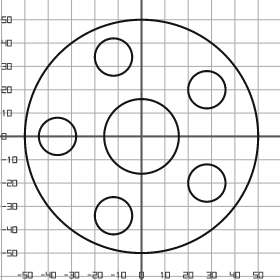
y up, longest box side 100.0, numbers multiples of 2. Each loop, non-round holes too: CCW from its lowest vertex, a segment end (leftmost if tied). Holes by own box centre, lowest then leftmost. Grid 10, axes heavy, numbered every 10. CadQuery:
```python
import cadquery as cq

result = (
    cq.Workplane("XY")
    .moveTo(0.0, 0.0)
    .circle(50.0)
    .moveTo(-12.0, -34.0)
    .circle(8.0)
    .moveTo(28.0, -20.0)
    .circle(8.0)
    .moveTo(-36.0, 0.0)
    .circle(8.0)
    .moveTo(0.0, 0.0)
    .circle(16.0)
    .moveTo(28.0, 20.0)
    .circle(8.0)
    .moveTo(-12.0, 34.0)
    .circle(8.0)
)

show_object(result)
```